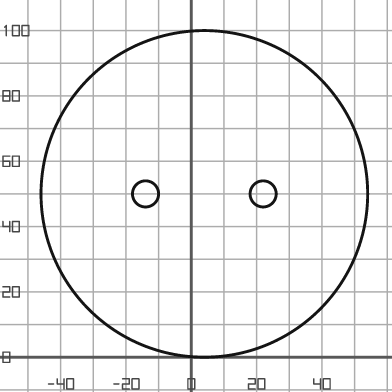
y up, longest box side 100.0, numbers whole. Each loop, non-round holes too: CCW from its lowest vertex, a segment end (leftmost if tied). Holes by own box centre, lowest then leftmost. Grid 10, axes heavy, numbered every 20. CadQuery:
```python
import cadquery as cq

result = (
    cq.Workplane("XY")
    .moveTo(4.0, 50.0)
    .circle(50.0)
    .moveTo(-14.0, 50.0)
    .circle(4.0)
    .moveTo(22.0, 50.0)
    .circle(4.0)
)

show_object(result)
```